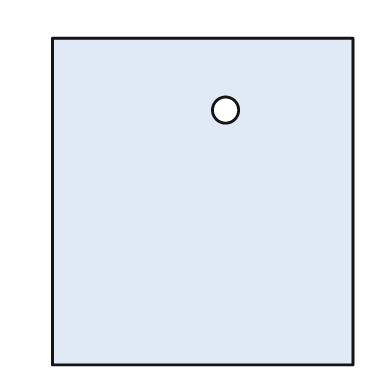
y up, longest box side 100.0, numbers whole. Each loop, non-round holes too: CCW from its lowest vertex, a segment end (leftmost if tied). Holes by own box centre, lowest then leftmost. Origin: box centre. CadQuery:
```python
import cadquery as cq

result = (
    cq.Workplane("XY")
    .moveTo(-46.0, -50.0)
    .lineTo(46.0, -50.0)
    .lineTo(46.0, 50.0)
    .lineTo(-46.0, 50.0)
    .close()
    .moveTo(7.0, 28.0)
    .circle(4.0)
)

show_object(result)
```